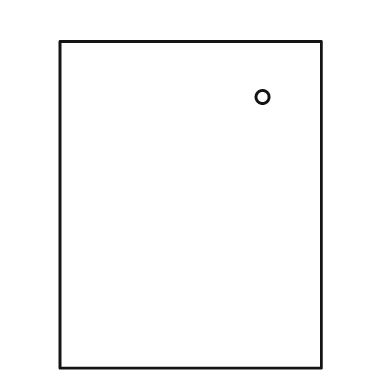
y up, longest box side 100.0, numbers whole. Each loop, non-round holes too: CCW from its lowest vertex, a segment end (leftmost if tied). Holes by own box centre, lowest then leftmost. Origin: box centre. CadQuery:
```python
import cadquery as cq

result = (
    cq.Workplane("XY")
    .moveTo(-40.0, -50.0)
    .lineTo(40.0, -50.0)
    .lineTo(40.0, 50.0)
    .lineTo(-40.0, 50.0)
    .close()
    .moveTo(22.0, 33.0)
    .circle(2.0)
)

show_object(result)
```